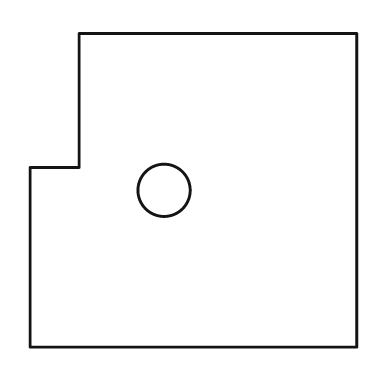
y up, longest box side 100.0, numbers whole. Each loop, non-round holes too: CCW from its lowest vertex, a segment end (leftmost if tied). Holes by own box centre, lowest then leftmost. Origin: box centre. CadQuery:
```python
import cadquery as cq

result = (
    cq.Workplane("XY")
    .moveTo(-50.0, -48.0)
    .lineTo(50.0, -48.0)
    .lineTo(50.0, 48.0)
    .lineTo(-35.0, 48.0)
    .lineTo(-35.0, 7.0)
    .lineTo(-50.0, 7.0)
    .close()
    .moveTo(-9.0, 0.0)
    .circle(8.0)
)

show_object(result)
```